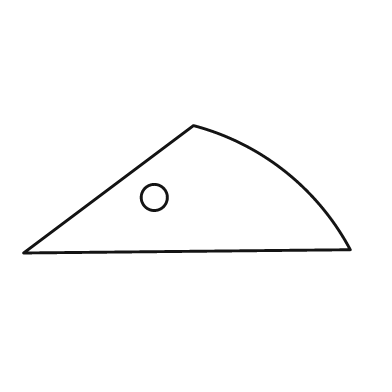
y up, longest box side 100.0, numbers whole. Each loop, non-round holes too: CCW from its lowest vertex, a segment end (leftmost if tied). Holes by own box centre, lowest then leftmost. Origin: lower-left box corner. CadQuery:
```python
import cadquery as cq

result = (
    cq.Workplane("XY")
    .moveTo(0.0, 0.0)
    .lineTo(100.0, 1.0)
    .threePointArc((80.0, 25.0), (52.0, 39.0))
    .close()
    .moveTo(40.0, 17.0)
    .circle(4.0)
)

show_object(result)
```